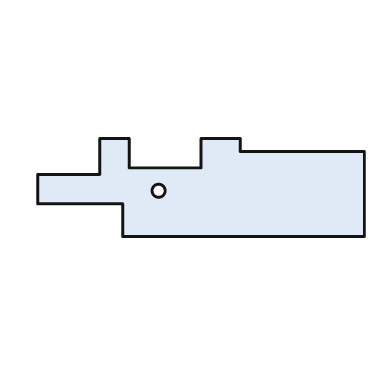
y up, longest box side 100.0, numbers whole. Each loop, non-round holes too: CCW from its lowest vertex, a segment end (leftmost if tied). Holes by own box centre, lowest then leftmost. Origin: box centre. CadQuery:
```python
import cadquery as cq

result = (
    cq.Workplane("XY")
    .moveTo(-24.0, -15.0)
    .lineTo(50.0, -15.0)
    .lineTo(50.0, 11.0)
    .lineTo(12.0, 11.0)
    .lineTo(12.0, 15.0)
    .lineTo(0.0, 15.0)
    .lineTo(0.0, 6.0)
    .lineTo(-22.0, 6.0)
    .lineTo(-22.0, 15.0)
    .lineTo(-31.0, 15.0)
    .lineTo(-31.0, 4.0)
    .lineTo(-50.0, 4.0)
    .lineTo(-50.0, -5.0)
    .lineTo(-24.0, -5.0)
    .close()
    .moveTo(-13.0, -1.0)
    .circle(2.0)
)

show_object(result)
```